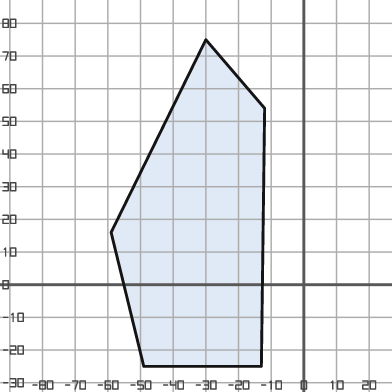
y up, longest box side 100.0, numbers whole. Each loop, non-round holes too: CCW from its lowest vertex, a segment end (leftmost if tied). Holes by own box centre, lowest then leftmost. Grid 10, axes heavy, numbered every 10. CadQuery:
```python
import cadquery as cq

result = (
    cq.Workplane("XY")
    .moveTo(-49.0, -25.0)
    .lineTo(-13.0, -25.0)
    .lineTo(-12.0, 54.0)
    .lineTo(-30.0, 75.0)
    .lineTo(-59.0, 16.0)
    .close()
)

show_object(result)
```